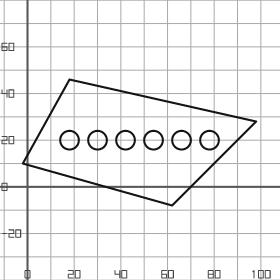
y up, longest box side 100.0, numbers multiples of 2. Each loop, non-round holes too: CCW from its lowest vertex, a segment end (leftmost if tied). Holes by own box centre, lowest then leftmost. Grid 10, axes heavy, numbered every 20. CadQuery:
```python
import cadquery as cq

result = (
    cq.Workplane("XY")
    .moveTo(62.0, -8.0)
    .lineTo(98.0, 28.0)
    .lineTo(18.0, 46.0)
    .lineTo(-2.0, 10.0)
    .close()
    .moveTo(18.0, 20.0)
    .circle(4.0)
    .moveTo(30.0, 20.0)
    .circle(4.0)
    .moveTo(42.0, 20.0)
    .circle(4.0)
    .moveTo(54.0, 20.0)
    .circle(4.0)
    .moveTo(66.0, 20.0)
    .circle(4.0)
    .moveTo(78.0, 20.0)
    .circle(4.0)
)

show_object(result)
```